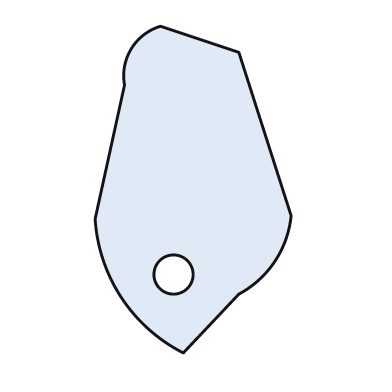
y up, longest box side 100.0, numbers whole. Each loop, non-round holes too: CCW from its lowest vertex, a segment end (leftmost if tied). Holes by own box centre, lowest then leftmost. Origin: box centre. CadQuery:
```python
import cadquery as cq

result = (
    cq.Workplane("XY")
    .moveTo(-3.0, -50.0)
    .lineTo(14.0, -32.0)
    .threePointArc((25.0, -22.0), (30.0, -8.0))
    .lineTo(14.0, 42.0)
    .lineTo(-10.0, 50.0)
    .threePointArc((-19.0, 43.0), (-21.0, 32.0))
    .lineTo(-30.0, -9.0)
    .threePointArc((-22.0, -33.0), (-3.0, -50.0))
    .close()
    .moveTo(-6.0, -26.0)
    .circle(6.0)
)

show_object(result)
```